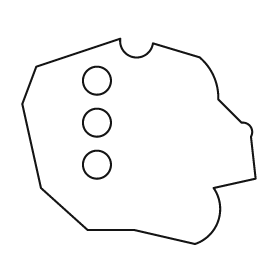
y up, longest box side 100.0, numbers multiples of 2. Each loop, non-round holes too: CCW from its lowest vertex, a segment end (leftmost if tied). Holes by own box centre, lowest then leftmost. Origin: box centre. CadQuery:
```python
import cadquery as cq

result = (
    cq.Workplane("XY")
    .moveTo(24.0, -44.0)
    .threePointArc((34.0, -34.0), (32.0, -20.0))
    .lineTo(50.0, -16.0)
    .lineTo(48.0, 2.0)
    .threePointArc((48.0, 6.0), (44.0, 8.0))
    .lineTo(34.0, 18.0)
    .threePointArc((32.0, 28.0), (26.0, 36.0))
    .lineTo(6.0, 42.0)
    .threePointArc((-2.0, 36.0), (-8.0, 44.0))
    .lineTo(-44.0, 32.0)
    .lineTo(-50.0, 16.0)
    .lineTo(-42.0, -20.0)
    .lineTo(-22.0, -38.0)
    .lineTo(-2.0, -38.0)
    .close()
    .moveTo(-18.0, -10.0)
    .circle(6.0)
    .moveTo(-18.0, 8.0)
    .circle(6.0)
    .moveTo(-18.0, 26.0)
    .circle(6.0)
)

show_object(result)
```